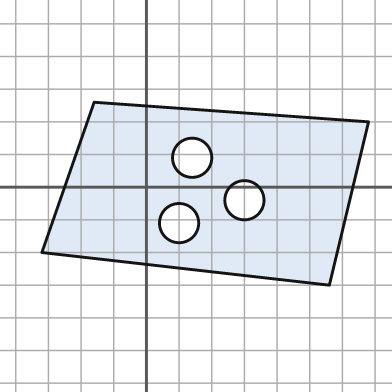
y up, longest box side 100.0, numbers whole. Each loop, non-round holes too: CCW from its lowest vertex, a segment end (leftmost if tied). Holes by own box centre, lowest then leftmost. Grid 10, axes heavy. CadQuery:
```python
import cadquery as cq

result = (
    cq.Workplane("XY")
    .moveTo(56.0, -30.0)
    .lineTo(68.0, 20.0)
    .lineTo(-16.0, 26.0)
    .lineTo(-32.0, -20.0)
    .close()
    .moveTo(10.0, -11.0)
    .circle(6.0)
    .moveTo(30.0, -4.0)
    .circle(6.0)
    .moveTo(14.0, 9.0)
    .circle(6.0)
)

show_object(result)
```